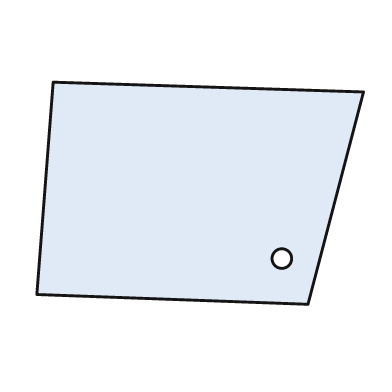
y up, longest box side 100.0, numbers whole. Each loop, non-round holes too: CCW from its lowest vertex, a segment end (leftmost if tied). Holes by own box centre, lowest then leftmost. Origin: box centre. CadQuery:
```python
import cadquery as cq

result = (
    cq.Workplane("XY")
    .moveTo(33.0, -34.0)
    .lineTo(50.0, 31.0)
    .lineTo(-45.0, 34.0)
    .lineTo(-50.0, -31.0)
    .close()
    .moveTo(25.0, -20.0)
    .circle(3.0)
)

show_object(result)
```